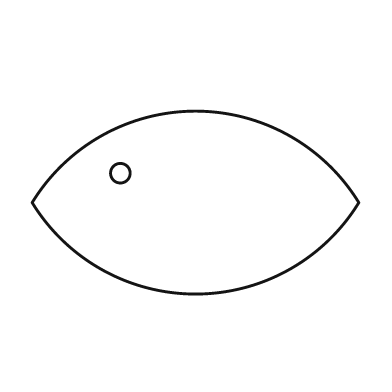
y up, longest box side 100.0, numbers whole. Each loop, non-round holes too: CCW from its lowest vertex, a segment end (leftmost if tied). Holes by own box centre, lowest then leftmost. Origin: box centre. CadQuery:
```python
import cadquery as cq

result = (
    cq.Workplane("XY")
    .moveTo(-50.0, 0.0)
    .threePointArc((0.0, -28.0), (50.0, 0.0))
    .threePointArc((0.0, 28.0), (-50.0, 0.0))
    .close()
    .moveTo(-23.0, 9.0)
    .circle(3.0)
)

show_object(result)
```